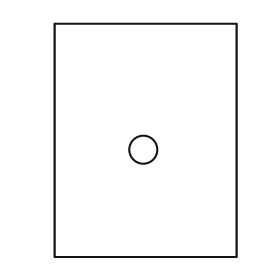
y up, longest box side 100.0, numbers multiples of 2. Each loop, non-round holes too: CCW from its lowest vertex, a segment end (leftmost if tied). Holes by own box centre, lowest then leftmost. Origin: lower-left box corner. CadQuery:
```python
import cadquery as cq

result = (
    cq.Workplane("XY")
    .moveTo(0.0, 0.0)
    .lineTo(78.0, 0.0)
    .lineTo(78.0, 100.0)
    .lineTo(0.0, 100.0)
    .close()
    .moveTo(38.0, 46.0)
    .circle(6.0)
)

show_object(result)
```